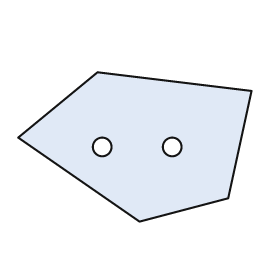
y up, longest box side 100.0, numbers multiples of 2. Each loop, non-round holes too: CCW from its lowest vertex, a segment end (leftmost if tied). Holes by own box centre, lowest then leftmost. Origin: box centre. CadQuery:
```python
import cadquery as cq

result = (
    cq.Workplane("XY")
    .moveTo(2.0, -32.0)
    .lineTo(40.0, -22.0)
    .lineTo(50.0, 24.0)
    .lineTo(-16.0, 32.0)
    .lineTo(-50.0, 4.0)
    .close()
    .moveTo(-14.0, 0.0)
    .circle(4.0)
    .moveTo(16.0, 0.0)
    .circle(4.0)
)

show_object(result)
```